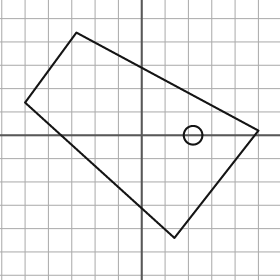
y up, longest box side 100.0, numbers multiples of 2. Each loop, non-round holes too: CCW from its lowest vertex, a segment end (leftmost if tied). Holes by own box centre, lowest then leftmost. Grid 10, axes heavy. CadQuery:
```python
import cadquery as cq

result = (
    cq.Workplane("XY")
    .moveTo(14.0, -44.0)
    .lineTo(50.0, 2.0)
    .lineTo(-28.0, 44.0)
    .lineTo(-50.0, 14.0)
    .close()
    .moveTo(22.0, 0.0)
    .circle(4.0)
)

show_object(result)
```